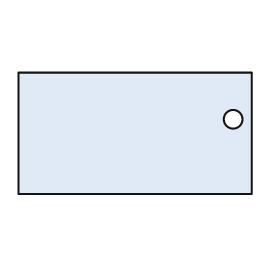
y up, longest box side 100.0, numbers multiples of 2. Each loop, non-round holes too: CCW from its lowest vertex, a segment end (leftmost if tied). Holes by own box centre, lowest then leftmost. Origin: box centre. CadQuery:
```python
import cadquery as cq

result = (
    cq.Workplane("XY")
    .moveTo(-50.0, -26.0)
    .lineTo(50.0, -26.0)
    .lineTo(50.0, 26.0)
    .lineTo(-50.0, 26.0)
    .close()
    .moveTo(42.0, 6.0)
    .circle(4.0)
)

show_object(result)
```